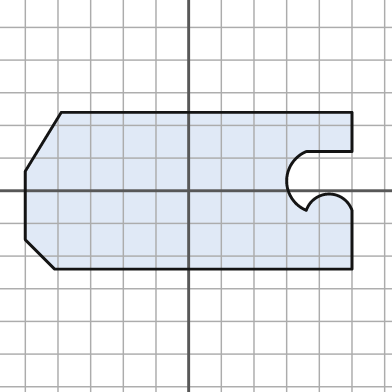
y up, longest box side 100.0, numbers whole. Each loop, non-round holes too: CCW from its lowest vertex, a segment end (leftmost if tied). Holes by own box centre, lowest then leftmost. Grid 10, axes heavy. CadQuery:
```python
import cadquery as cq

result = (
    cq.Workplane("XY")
    .moveTo(-41.0, -24.0)
    .lineTo(50.0, -24.0)
    .lineTo(50.0, -6.0)
    .threePointArc((43.0, -1.0), (36.0, -6.0))
    .threePointArc((30.0, 3.0), (36.0, 12.0))
    .lineTo(50.0, 12.0)
    .lineTo(50.0, 24.0)
    .lineTo(-39.0, 24.0)
    .lineTo(-50.0, 6.0)
    .lineTo(-50.0, -15.0)
    .close()
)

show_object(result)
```